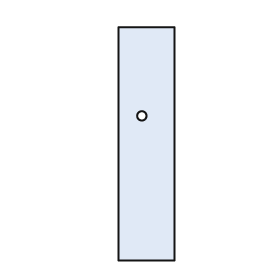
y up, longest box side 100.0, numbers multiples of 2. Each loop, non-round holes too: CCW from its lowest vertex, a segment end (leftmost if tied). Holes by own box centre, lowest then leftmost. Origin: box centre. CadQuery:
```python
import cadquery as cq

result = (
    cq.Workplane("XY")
    .moveTo(-12.0, -50.0)
    .lineTo(12.0, -50.0)
    .lineTo(12.0, 50.0)
    .lineTo(-12.0, 50.0)
    .close()
    .moveTo(-2.0, 12.0)
    .circle(2.0)
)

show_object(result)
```